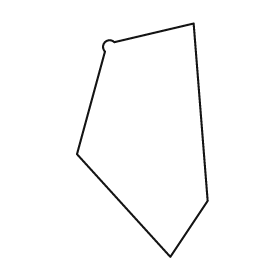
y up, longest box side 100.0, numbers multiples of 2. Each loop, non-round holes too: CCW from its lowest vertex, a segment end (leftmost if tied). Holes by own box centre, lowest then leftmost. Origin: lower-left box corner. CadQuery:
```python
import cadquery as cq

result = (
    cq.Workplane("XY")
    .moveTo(40.0, 0.0)
    .lineTo(56.0, 24.0)
    .lineTo(50.0, 100.0)
    .lineTo(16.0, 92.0)
    .threePointArc((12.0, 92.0), (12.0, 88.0))
    .lineTo(0.0, 44.0)
    .close()
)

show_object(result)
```